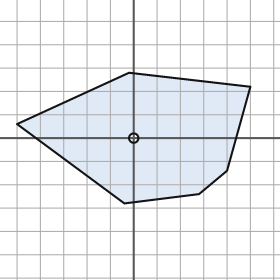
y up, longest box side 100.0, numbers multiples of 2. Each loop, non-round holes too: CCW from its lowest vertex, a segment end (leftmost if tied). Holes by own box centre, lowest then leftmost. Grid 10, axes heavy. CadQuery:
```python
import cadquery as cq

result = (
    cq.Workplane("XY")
    .moveTo(-4.0, -28.0)
    .lineTo(28.0, -24.0)
    .lineTo(40.0, -14.0)
    .lineTo(50.0, 22.0)
    .lineTo(-2.0, 28.0)
    .lineTo(-50.0, 6.0)
    .close()
    .moveTo(0.0, 0.0)
    .circle(2.0)
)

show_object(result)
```